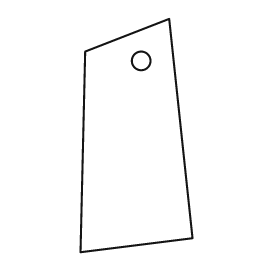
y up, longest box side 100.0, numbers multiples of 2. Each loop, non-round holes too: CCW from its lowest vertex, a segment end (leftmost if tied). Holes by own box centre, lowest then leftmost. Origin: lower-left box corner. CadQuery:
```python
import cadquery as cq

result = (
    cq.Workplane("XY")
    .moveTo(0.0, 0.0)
    .lineTo(48.0, 6.0)
    .lineTo(38.0, 100.0)
    .lineTo(2.0, 86.0)
    .close()
    .moveTo(26.0, 82.0)
    .circle(4.0)
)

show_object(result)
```